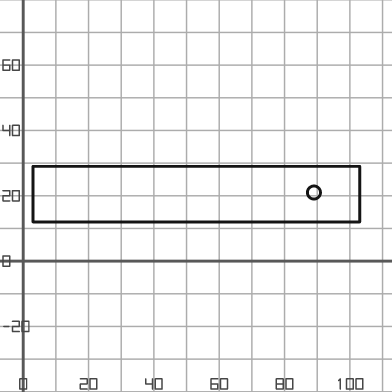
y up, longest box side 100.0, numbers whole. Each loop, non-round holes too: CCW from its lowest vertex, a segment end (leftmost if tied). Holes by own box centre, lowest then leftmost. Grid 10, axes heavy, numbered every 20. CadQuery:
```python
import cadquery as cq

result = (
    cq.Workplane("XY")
    .moveTo(3.0, 12.0)
    .lineTo(103.0, 12.0)
    .lineTo(103.0, 29.0)
    .lineTo(3.0, 29.0)
    .close()
    .moveTo(89.0, 21.0)
    .circle(2.0)
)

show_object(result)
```